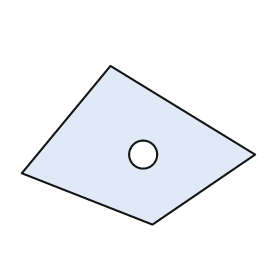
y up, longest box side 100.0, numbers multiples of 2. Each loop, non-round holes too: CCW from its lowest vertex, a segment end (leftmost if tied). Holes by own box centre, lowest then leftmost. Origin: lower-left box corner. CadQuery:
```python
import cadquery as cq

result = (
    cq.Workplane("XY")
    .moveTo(56.0, 0.0)
    .lineTo(100.0, 30.0)
    .lineTo(38.0, 68.0)
    .lineTo(0.0, 22.0)
    .close()
    .moveTo(52.0, 30.0)
    .circle(6.0)
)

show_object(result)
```